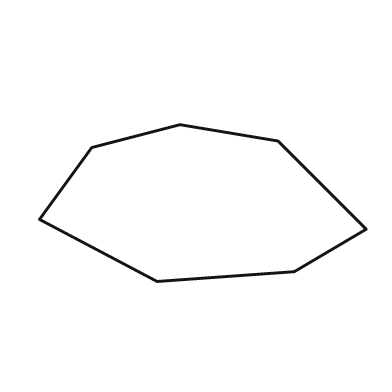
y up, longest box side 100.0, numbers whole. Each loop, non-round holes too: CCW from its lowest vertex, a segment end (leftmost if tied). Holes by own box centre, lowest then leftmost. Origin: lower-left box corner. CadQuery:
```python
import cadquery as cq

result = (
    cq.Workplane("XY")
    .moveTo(36.0, 0.0)
    .lineTo(78.0, 3.0)
    .lineTo(100.0, 16.0)
    .lineTo(73.0, 43.0)
    .lineTo(43.0, 48.0)
    .lineTo(16.0, 41.0)
    .lineTo(0.0, 19.0)
    .close()
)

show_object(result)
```